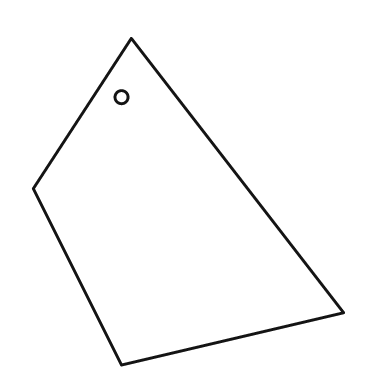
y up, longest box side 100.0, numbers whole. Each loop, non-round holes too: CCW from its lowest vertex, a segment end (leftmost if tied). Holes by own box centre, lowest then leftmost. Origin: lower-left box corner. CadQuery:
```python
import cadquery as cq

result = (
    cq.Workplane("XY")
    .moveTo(27.0, 0.0)
    .lineTo(95.0, 16.0)
    .lineTo(30.0, 100.0)
    .lineTo(0.0, 54.0)
    .close()
    .moveTo(27.0, 82.0)
    .circle(2.0)
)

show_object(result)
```